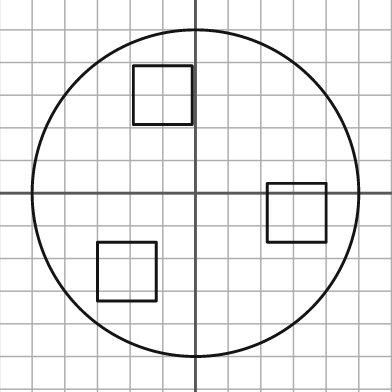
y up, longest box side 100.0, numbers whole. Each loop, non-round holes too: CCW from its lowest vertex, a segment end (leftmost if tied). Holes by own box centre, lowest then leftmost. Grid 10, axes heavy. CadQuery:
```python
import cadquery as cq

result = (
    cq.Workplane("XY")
    .moveTo(0.0, 0.0)
    .circle(50.0)
    .moveTo(-30.0, -33.0)
    .lineTo(-12.0, -33.0)
    .lineTo(-12.0, -15.0)
    .lineTo(-30.0, -15.0)
    .close()
    .moveTo(22.0, -15.0)
    .lineTo(40.0, -15.0)
    .lineTo(40.0, 3.0)
    .lineTo(22.0, 3.0)
    .close()
    .moveTo(-19.0, 21.0)
    .lineTo(-1.0, 21.0)
    .lineTo(-1.0, 39.0)
    .lineTo(-19.0, 39.0)
    .close()
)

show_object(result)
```